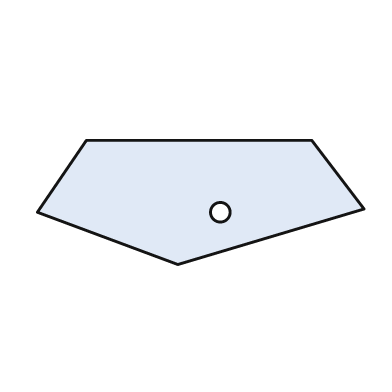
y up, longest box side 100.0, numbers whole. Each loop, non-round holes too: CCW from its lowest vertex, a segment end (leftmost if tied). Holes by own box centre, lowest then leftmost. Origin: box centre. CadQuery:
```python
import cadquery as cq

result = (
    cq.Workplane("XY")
    .moveTo(-7.0, -19.0)
    .lineTo(50.0, -2.0)
    .lineTo(34.0, 19.0)
    .lineTo(-35.0, 19.0)
    .lineTo(-50.0, -3.0)
    .close()
    .moveTo(6.0, -3.0)
    .circle(3.0)
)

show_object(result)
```